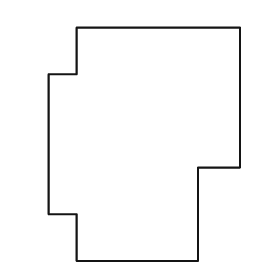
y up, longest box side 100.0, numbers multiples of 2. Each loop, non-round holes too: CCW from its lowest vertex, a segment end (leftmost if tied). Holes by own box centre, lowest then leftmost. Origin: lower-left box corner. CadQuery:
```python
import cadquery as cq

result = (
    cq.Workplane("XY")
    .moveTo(12.0, 0.0)
    .lineTo(64.0, 0.0)
    .lineTo(64.0, 40.0)
    .lineTo(82.0, 40.0)
    .lineTo(82.0, 100.0)
    .lineTo(12.0, 100.0)
    .lineTo(12.0, 80.0)
    .lineTo(0.0, 80.0)
    .lineTo(0.0, 20.0)
    .lineTo(12.0, 20.0)
    .close()
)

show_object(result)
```